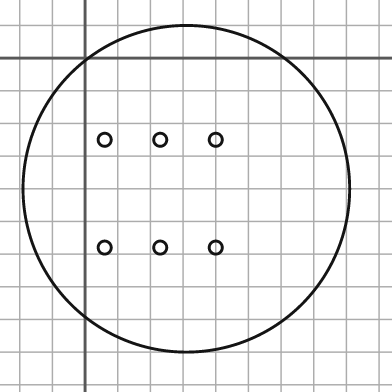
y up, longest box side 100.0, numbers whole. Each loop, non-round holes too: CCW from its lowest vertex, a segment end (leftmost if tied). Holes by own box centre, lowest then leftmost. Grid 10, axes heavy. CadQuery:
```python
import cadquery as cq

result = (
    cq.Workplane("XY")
    .moveTo(31.0, -40.0)
    .circle(50.0)
    .moveTo(6.0, -58.0)
    .circle(2.0)
    .moveTo(23.0, -58.0)
    .circle(2.0)
    .moveTo(40.0, -58.0)
    .circle(2.0)
    .moveTo(6.0, -25.0)
    .circle(2.0)
    .moveTo(23.0, -25.0)
    .circle(2.0)
    .moveTo(40.0, -25.0)
    .circle(2.0)
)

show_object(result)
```